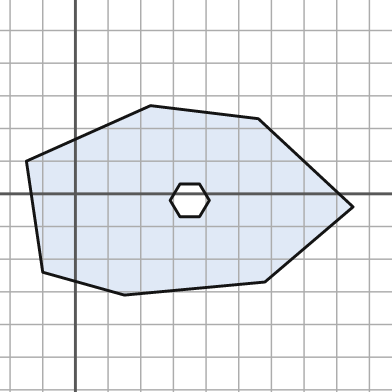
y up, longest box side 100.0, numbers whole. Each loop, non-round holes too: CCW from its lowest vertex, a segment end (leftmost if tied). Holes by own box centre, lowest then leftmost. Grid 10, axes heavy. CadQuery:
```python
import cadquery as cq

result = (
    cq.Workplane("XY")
    .moveTo(15.0, -31.0)
    .lineTo(58.0, -27.0)
    .lineTo(85.0, -4.0)
    .lineTo(56.0, 23.0)
    .lineTo(23.0, 27.0)
    .lineTo(-15.0, 10.0)
    .lineTo(-10.0, -24.0)
    .close()
    .moveTo(32.0, -7.0)
    .lineTo(38.0, -7.0)
    .lineTo(41.0, -2.0)
    .lineTo(38.0, 3.0)
    .lineTo(32.0, 3.0)
    .lineTo(29.0, -2.0)
    .close()
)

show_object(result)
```